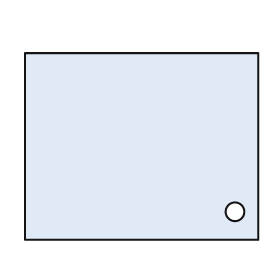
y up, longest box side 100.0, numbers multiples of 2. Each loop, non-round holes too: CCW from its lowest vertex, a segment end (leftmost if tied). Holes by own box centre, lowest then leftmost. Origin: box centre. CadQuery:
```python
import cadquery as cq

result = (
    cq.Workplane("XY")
    .moveTo(-50.0, -40.0)
    .lineTo(50.0, -40.0)
    .lineTo(50.0, 40.0)
    .lineTo(-50.0, 40.0)
    .close()
    .moveTo(40.0, -28.0)
    .circle(4.0)
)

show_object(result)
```